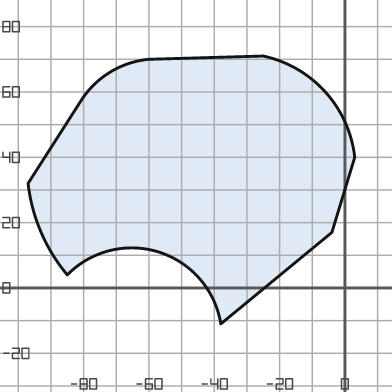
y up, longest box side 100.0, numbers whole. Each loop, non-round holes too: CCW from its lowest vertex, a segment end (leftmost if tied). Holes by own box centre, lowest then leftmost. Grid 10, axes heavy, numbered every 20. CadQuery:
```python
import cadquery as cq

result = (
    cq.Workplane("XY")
    .moveTo(-38.0, -11.0)
    .lineTo(-4.0, 17.0)
    .lineTo(3.0, 40.0)
    .threePointArc((-6.0, 60.0), (-25.0, 71.0))
    .lineTo(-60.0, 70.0)
    .threePointArc((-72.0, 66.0), (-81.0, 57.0))
    .lineTo(-97.0, 32.0)
    .threePointArc((-93.0, 17.0), (-85.0, 4.0))
    .threePointArc((-57.0, 11.0), (-38.0, -11.0))
    .close()
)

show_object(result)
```